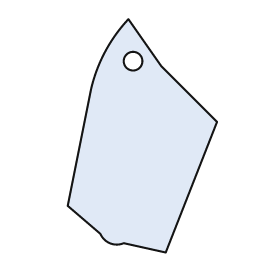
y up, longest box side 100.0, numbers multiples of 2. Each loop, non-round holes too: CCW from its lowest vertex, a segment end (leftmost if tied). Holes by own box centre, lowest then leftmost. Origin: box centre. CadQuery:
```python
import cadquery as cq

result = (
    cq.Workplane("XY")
    .moveTo(10.0, -50.0)
    .lineTo(32.0, 6.0)
    .lineTo(8.0, 30.0)
    .lineTo(-6.0, 50.0)
    .threePointArc((-16.0, 36.0), (-22.0, 20.0))
    .lineTo(-32.0, -30.0)
    .lineTo(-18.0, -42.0)
    .threePointArc((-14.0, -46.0), (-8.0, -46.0))
    .close()
    .moveTo(-4.0, 32.0)
    .circle(4.0)
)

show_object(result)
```